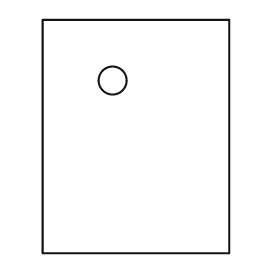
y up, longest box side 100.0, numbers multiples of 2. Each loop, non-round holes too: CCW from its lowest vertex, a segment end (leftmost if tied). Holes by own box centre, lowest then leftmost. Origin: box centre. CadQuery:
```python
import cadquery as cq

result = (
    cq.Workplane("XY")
    .moveTo(-40.0, -50.0)
    .lineTo(40.0, -50.0)
    .lineTo(40.0, 50.0)
    .lineTo(-40.0, 50.0)
    .close()
    .moveTo(-10.0, 24.0)
    .circle(6.0)
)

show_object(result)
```